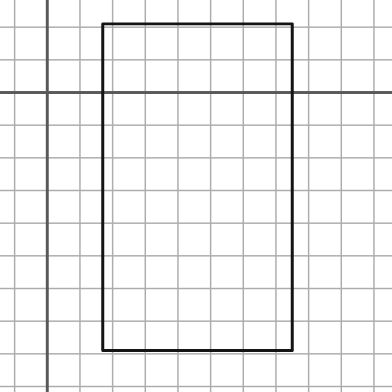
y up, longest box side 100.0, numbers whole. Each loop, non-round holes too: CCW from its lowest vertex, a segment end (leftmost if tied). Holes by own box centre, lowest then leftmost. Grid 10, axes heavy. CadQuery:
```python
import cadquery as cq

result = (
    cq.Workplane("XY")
    .moveTo(17.0, -79.0)
    .lineTo(75.0, -79.0)
    .lineTo(75.0, 21.0)
    .lineTo(17.0, 21.0)
    .close()
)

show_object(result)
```